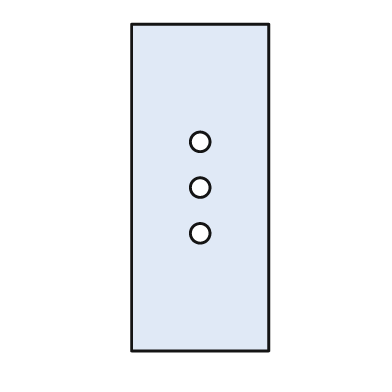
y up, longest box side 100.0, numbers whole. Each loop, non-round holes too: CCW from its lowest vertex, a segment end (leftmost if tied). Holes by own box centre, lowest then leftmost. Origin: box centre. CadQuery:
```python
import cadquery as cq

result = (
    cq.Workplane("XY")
    .moveTo(-21.0, -50.0)
    .lineTo(21.0, -50.0)
    .lineTo(21.0, 50.0)
    .lineTo(-21.0, 50.0)
    .close()
    .moveTo(0.0, -14.0)
    .circle(3.0)
    .moveTo(0.0, 0.0)
    .circle(3.0)
    .moveTo(0.0, 14.0)
    .circle(3.0)
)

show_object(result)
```